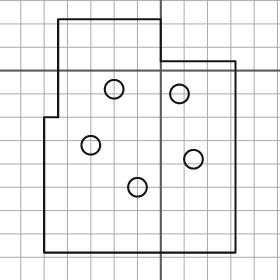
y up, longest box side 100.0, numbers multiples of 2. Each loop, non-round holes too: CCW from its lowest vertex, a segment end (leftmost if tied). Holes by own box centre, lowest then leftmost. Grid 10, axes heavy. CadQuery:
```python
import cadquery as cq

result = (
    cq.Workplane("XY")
    .moveTo(-50.0, -78.0)
    .lineTo(32.0, -78.0)
    .lineTo(32.0, 4.0)
    .lineTo(0.0, 4.0)
    .lineTo(0.0, 22.0)
    .lineTo(-44.0, 22.0)
    .lineTo(-44.0, -20.0)
    .lineTo(-50.0, -20.0)
    .close()
    .moveTo(-10.0, -50.0)
    .circle(4.0)
    .moveTo(14.0, -38.0)
    .circle(4.0)
    .moveTo(-30.0, -32.0)
    .circle(4.0)
    .moveTo(8.0, -10.0)
    .circle(4.0)
    .moveTo(-20.0, -8.0)
    .circle(4.0)
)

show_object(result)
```